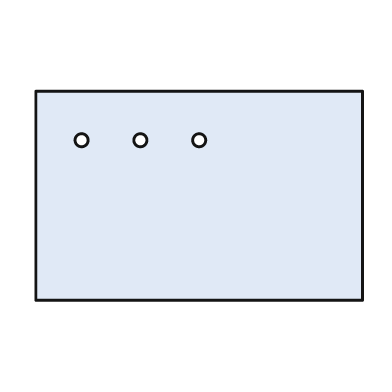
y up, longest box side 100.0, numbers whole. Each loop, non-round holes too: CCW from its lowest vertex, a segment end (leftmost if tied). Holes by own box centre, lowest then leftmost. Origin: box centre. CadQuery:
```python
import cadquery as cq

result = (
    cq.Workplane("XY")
    .moveTo(-50.0, -32.0)
    .lineTo(50.0, -32.0)
    .lineTo(50.0, 32.0)
    .lineTo(-50.0, 32.0)
    .close()
    .moveTo(-36.0, 17.0)
    .circle(2.0)
    .moveTo(-18.0, 17.0)
    .circle(2.0)
    .moveTo(0.0, 17.0)
    .circle(2.0)
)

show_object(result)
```